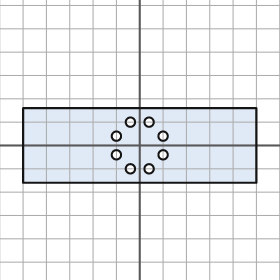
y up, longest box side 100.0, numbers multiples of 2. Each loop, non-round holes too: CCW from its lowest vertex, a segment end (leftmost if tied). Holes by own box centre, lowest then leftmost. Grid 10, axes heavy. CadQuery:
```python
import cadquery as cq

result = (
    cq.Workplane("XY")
    .moveTo(-50.0, -16.0)
    .lineTo(50.0, -16.0)
    .lineTo(50.0, 16.0)
    .lineTo(-50.0, 16.0)
    .close()
    .moveTo(-4.0, -10.0)
    .circle(2.0)
    .moveTo(4.0, -10.0)
    .circle(2.0)
    .moveTo(-10.0, -4.0)
    .circle(2.0)
    .moveTo(10.0, -4.0)
    .circle(2.0)
    .moveTo(-10.0, 4.0)
    .circle(2.0)
    .moveTo(10.0, 4.0)
    .circle(2.0)
    .moveTo(-4.0, 10.0)
    .circle(2.0)
    .moveTo(4.0, 10.0)
    .circle(2.0)
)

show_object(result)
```